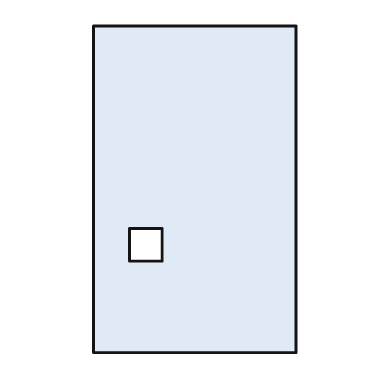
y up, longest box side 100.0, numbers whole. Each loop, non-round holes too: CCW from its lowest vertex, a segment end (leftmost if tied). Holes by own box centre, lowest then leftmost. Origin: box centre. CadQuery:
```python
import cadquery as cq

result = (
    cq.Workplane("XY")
    .moveTo(-31.0, -50.0)
    .lineTo(31.0, -50.0)
    .lineTo(31.0, 50.0)
    .lineTo(-31.0, 50.0)
    .close()
    .moveTo(-20.0, -22.0)
    .lineTo(-10.0, -22.0)
    .lineTo(-10.0, -12.0)
    .lineTo(-20.0, -12.0)
    .close()
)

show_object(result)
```